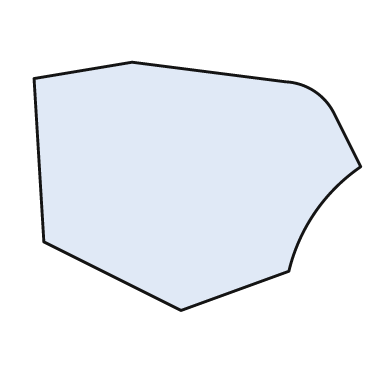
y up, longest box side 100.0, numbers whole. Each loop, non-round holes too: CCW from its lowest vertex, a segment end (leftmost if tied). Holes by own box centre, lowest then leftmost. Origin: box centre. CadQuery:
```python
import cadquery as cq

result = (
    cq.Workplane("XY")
    .moveTo(-5.0, -38.0)
    .lineTo(28.0, -26.0)
    .threePointArc((36.0, -8.0), (50.0, 6.0))
    .lineTo(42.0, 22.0)
    .threePointArc((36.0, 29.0), (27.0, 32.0))
    .lineTo(-20.0, 38.0)
    .lineTo(-50.0, 33.0)
    .lineTo(-47.0, -17.0)
    .close()
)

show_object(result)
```